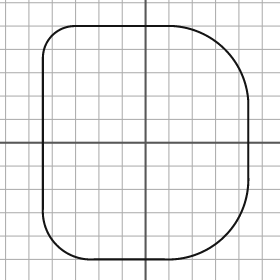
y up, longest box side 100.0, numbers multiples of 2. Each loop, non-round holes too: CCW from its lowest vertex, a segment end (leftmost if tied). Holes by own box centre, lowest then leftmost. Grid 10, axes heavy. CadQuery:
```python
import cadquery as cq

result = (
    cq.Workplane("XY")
    .moveTo(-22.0, -50.0)
    .lineTo(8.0, -50.0)
    .threePointArc((34.0, -40.0), (44.0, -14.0))
    .lineTo(44.0, 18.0)
    .threePointArc((34.0, 40.0), (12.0, 50.0))
    .lineTo(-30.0, 50.0)
    .threePointArc((-40.0, 46.0), (-44.0, 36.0))
    .lineTo(-44.0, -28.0)
    .threePointArc((-38.0, -44.0), (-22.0, -50.0))
    .close()
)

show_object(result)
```